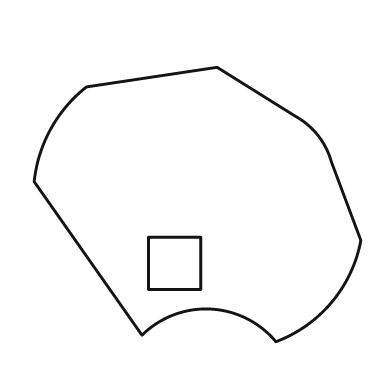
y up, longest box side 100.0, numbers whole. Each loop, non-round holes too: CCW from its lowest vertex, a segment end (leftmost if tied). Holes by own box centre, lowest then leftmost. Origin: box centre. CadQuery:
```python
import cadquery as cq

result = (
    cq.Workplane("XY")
    .moveTo(24.0, -42.0)
    .threePointArc((41.0, -30.0), (50.0, -11.0))
    .lineTo(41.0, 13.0)
    .threePointArc((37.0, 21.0), (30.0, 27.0))
    .lineTo(6.0, 42.0)
    .lineTo(-34.0, 36.0)
    .threePointArc((-45.0, 23.0), (-50.0, 7.0))
    .lineTo(-17.0, -40.0)
    .threePointArc((4.0, -32.0), (24.0, -42.0))
    .close()
    .moveTo(-15.0, -26.0)
    .lineTo(1.0, -26.0)
    .lineTo(1.0, -10.0)
    .lineTo(-15.0, -10.0)
    .close()
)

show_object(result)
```